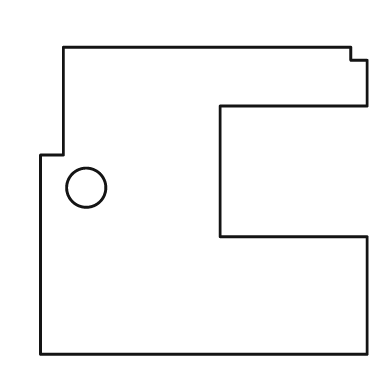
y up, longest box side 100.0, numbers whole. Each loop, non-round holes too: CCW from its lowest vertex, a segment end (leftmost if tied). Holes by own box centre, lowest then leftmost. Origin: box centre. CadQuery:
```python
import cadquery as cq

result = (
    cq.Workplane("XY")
    .moveTo(-50.0, -47.0)
    .lineTo(50.0, -47.0)
    .lineTo(50.0, -11.0)
    .lineTo(5.0, -11.0)
    .lineTo(5.0, 29.0)
    .lineTo(50.0, 29.0)
    .lineTo(50.0, 43.0)
    .lineTo(45.0, 43.0)
    .lineTo(45.0, 47.0)
    .lineTo(-43.0, 47.0)
    .lineTo(-43.0, 14.0)
    .lineTo(-50.0, 14.0)
    .close()
    .moveTo(-36.0, 4.0)
    .circle(6.0)
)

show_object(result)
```